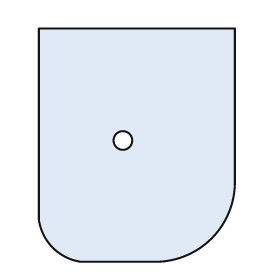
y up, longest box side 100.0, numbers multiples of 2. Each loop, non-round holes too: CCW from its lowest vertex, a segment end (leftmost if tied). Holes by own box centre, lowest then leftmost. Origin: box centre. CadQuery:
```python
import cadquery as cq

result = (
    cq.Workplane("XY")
    .moveTo(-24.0, -50.0)
    .lineTo(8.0, -50.0)
    .threePointArc((32.0, -40.0), (42.0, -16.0))
    .lineTo(42.0, 50.0)
    .lineTo(-42.0, 50.0)
    .lineTo(-42.0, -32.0)
    .threePointArc((-36.0, -44.0), (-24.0, -50.0))
    .close()
    .moveTo(-6.0, 2.0)
    .circle(4.0)
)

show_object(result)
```